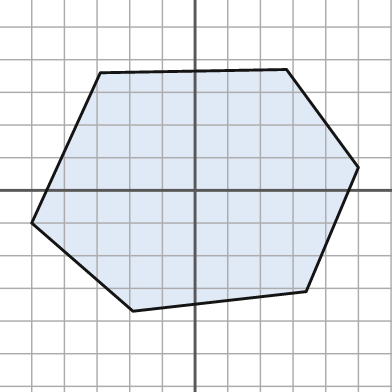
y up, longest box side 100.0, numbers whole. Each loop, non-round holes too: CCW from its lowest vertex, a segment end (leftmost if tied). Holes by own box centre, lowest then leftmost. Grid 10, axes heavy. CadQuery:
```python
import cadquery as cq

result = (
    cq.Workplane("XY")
    .moveTo(-19.0, -37.0)
    .lineTo(34.0, -31.0)
    .lineTo(50.0, 7.0)
    .lineTo(28.0, 37.0)
    .lineTo(-29.0, 36.0)
    .lineTo(-50.0, -10.0)
    .close()
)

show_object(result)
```